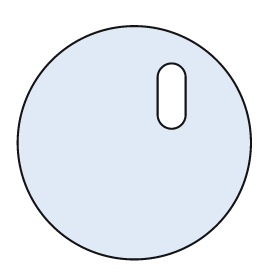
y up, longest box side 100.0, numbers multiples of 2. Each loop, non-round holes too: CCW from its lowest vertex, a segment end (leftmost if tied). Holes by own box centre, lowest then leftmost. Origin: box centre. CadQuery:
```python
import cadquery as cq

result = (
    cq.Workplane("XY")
    .moveTo(0.0, 0.0)
    .circle(50.0)
    .moveTo(10.0, 12.0)
    .threePointArc((16.0, 6.0), (22.0, 12.0))
    .lineTo(22.0, 28.0)
    .threePointArc((16.0, 34.0), (10.0, 28.0))
    .close()
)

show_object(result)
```